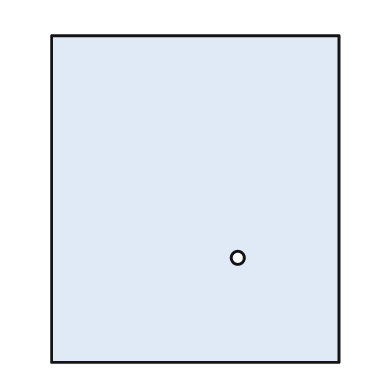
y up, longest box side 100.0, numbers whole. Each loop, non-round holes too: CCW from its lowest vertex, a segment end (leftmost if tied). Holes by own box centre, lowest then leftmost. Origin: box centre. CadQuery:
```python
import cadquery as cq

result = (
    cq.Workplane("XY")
    .moveTo(-44.0, -50.0)
    .lineTo(44.0, -50.0)
    .lineTo(44.0, 50.0)
    .lineTo(-44.0, 50.0)
    .close()
    .moveTo(13.0, -18.0)
    .circle(2.0)
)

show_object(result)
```